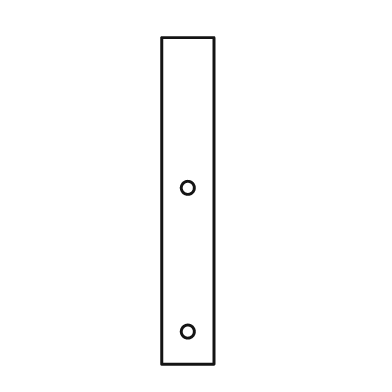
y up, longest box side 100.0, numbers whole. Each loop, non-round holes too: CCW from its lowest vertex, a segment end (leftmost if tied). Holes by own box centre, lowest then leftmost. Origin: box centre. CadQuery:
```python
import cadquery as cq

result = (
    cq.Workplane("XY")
    .moveTo(-8.0, -50.0)
    .lineTo(8.0, -50.0)
    .lineTo(8.0, 50.0)
    .lineTo(-8.0, 50.0)
    .close()
    .moveTo(0.0, -40.0)
    .circle(2.0)
    .moveTo(0.0, 4.0)
    .circle(2.0)
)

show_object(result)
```